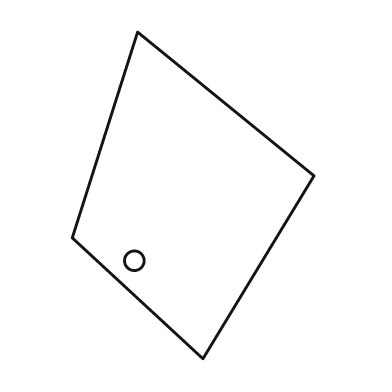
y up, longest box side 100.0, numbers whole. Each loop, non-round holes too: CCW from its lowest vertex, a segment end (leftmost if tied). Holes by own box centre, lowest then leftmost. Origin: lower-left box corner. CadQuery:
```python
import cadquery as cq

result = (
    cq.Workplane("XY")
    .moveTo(40.0, 0.0)
    .lineTo(74.0, 56.0)
    .lineTo(20.0, 100.0)
    .lineTo(0.0, 37.0)
    .close()
    .moveTo(19.0, 30.0)
    .circle(3.0)
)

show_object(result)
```